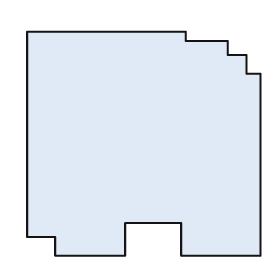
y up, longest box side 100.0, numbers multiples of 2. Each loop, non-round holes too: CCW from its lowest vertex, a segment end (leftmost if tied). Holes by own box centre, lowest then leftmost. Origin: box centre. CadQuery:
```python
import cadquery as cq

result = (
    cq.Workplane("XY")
    .moveTo(-38.0, -48.0)
    .lineTo(-8.0, -48.0)
    .lineTo(-8.0, -34.0)
    .lineTo(16.0, -34.0)
    .lineTo(16.0, -48.0)
    .lineTo(50.0, -48.0)
    .lineTo(50.0, 30.0)
    .lineTo(44.0, 30.0)
    .lineTo(44.0, 38.0)
    .lineTo(36.0, 38.0)
    .lineTo(36.0, 44.0)
    .lineTo(18.0, 44.0)
    .lineTo(18.0, 48.0)
    .lineTo(-50.0, 48.0)
    .lineTo(-50.0, -40.0)
    .lineTo(-38.0, -40.0)
    .close()
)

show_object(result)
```